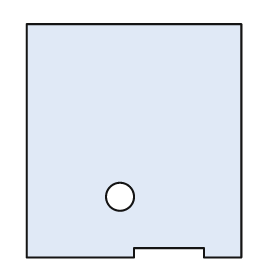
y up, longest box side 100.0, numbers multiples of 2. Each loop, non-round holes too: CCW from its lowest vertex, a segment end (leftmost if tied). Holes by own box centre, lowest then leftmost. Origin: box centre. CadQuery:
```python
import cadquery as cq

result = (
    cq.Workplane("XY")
    .moveTo(-46.0, -50.0)
    .lineTo(0.0, -50.0)
    .lineTo(0.0, -46.0)
    .lineTo(30.0, -46.0)
    .lineTo(30.0, -50.0)
    .lineTo(46.0, -50.0)
    .lineTo(46.0, 50.0)
    .lineTo(-46.0, 50.0)
    .close()
    .moveTo(-6.0, -24.0)
    .circle(6.0)
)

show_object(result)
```